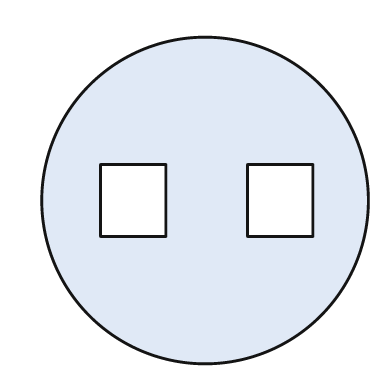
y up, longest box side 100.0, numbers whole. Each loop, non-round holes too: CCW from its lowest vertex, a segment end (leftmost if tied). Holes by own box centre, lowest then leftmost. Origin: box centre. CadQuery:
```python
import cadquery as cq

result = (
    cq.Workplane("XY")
    .moveTo(0.0, 0.0)
    .circle(50.0)
    .moveTo(-32.0, -11.0)
    .lineTo(-12.0, -11.0)
    .lineTo(-12.0, 11.0)
    .lineTo(-32.0, 11.0)
    .close()
    .moveTo(13.0, -11.0)
    .lineTo(33.0, -11.0)
    .lineTo(33.0, 11.0)
    .lineTo(13.0, 11.0)
    .close()
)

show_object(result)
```